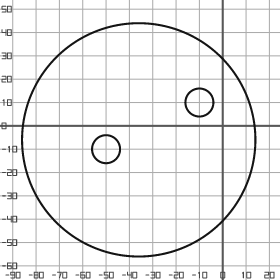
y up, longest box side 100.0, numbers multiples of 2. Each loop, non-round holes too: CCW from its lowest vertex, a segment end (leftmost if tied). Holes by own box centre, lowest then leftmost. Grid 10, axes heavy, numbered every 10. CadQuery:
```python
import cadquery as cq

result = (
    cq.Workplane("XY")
    .moveTo(-36.0, -6.0)
    .circle(50.0)
    .moveTo(-50.0, -10.0)
    .circle(6.0)
    .moveTo(-10.0, 10.0)
    .circle(6.0)
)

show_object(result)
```